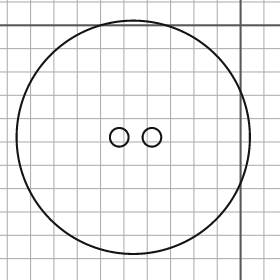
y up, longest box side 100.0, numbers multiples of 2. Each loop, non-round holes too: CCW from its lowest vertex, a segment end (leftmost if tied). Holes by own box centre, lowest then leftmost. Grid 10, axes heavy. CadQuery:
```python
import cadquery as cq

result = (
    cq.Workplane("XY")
    .moveTo(-46.0, -48.0)
    .circle(50.0)
    .moveTo(-52.0, -48.0)
    .circle(4.0)
    .moveTo(-38.0, -48.0)
    .circle(4.0)
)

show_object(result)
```